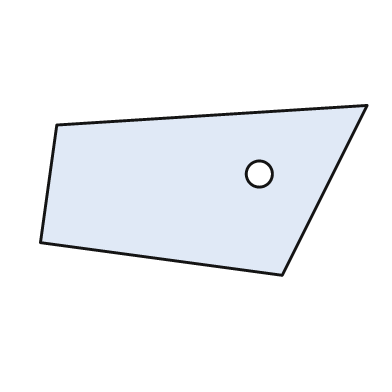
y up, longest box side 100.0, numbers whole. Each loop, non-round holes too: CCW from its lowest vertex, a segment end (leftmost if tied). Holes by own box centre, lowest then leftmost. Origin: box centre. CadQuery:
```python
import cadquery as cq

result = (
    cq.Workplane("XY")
    .moveTo(24.0, -26.0)
    .lineTo(50.0, 26.0)
    .lineTo(-45.0, 20.0)
    .lineTo(-50.0, -16.0)
    .close()
    .moveTo(17.0, 5.0)
    .circle(4.0)
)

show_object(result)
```